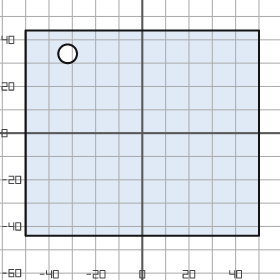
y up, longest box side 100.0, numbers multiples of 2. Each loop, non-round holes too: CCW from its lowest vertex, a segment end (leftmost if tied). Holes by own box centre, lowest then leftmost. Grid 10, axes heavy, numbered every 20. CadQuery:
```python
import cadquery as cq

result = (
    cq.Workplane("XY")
    .moveTo(-50.0, -44.0)
    .lineTo(50.0, -44.0)
    .lineTo(50.0, 44.0)
    .lineTo(-50.0, 44.0)
    .close()
    .moveTo(-32.0, 34.0)
    .circle(4.0)
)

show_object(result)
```